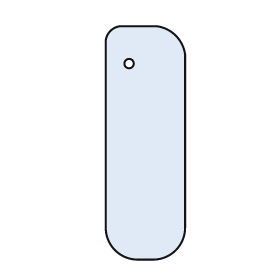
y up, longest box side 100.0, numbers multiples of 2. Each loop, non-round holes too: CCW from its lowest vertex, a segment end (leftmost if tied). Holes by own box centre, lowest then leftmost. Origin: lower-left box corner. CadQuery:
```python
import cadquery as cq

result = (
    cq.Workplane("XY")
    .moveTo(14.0, 0.0)
    .lineTo(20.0, 0.0)
    .threePointArc((30.0, 4.0), (34.0, 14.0))
    .lineTo(34.0, 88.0)
    .threePointArc((30.0, 96.0), (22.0, 100.0))
    .lineTo(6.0, 100.0)
    .threePointArc((2.0, 98.0), (0.0, 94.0))
    .lineTo(0.0, 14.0)
    .threePointArc((4.0, 4.0), (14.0, 0.0))
    .close()
    .moveTo(10.0, 84.0)
    .circle(2.0)
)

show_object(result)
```